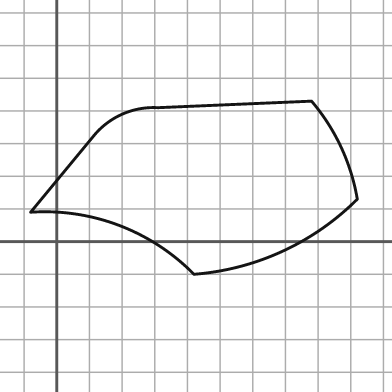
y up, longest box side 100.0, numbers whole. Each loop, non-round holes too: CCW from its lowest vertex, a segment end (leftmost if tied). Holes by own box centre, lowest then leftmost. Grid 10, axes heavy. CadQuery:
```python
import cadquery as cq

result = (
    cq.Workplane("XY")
    .moveTo(42.0, -10.0)
    .threePointArc((69.0, -3.0), (92.0, 13.0))
    .threePointArc((87.0, 29.0), (78.0, 43.0))
    .lineTo(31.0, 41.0)
    .threePointArc((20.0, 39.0), (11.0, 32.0))
    .lineTo(-8.0, 9.0)
    .threePointArc((19.0, 5.0), (42.0, -10.0))
    .close()
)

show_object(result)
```